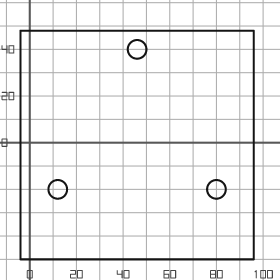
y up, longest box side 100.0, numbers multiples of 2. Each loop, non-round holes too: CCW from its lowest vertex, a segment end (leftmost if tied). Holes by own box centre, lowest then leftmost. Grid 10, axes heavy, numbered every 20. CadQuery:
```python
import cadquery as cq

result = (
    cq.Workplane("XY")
    .moveTo(-4.0, -50.0)
    .lineTo(96.0, -50.0)
    .lineTo(96.0, 48.0)
    .lineTo(-4.0, 48.0)
    .close()
    .moveTo(12.0, -20.0)
    .circle(4.0)
    .moveTo(80.0, -20.0)
    .circle(4.0)
    .moveTo(46.0, 40.0)
    .circle(4.0)
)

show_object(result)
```